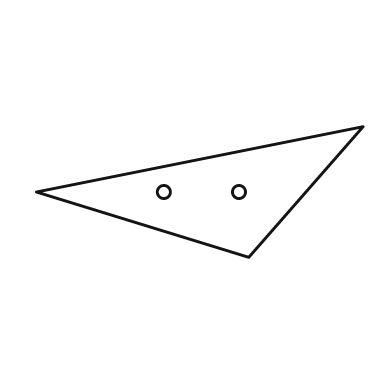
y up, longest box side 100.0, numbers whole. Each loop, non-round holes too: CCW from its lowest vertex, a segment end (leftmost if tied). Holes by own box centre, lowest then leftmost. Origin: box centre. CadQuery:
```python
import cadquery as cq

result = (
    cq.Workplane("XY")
    .moveTo(15.0, -20.0)
    .lineTo(50.0, 20.0)
    .lineTo(-50.0, 0.0)
    .close()
    .moveTo(-11.0, 0.0)
    .circle(2.0)
    .moveTo(12.0, 0.0)
    .circle(2.0)
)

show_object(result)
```